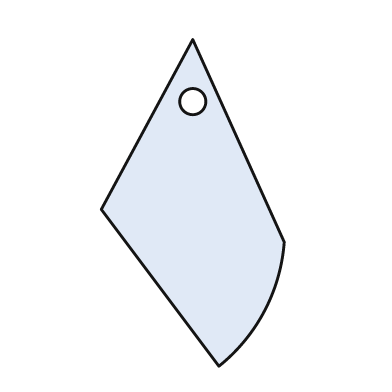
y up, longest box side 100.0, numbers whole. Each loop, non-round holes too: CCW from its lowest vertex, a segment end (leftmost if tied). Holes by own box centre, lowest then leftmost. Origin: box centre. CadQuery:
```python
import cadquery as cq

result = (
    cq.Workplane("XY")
    .moveTo(8.0, -50.0)
    .threePointArc((22.0, -33.0), (28.0, -12.0))
    .lineTo(0.0, 50.0)
    .lineTo(-28.0, -2.0)
    .close()
    .moveTo(0.0, 31.0)
    .circle(4.0)
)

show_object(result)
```